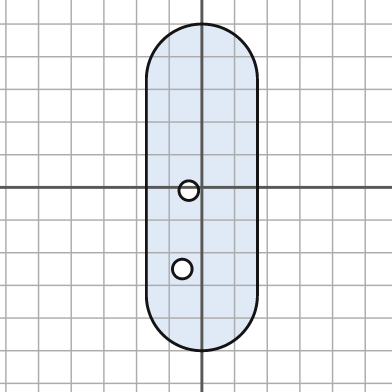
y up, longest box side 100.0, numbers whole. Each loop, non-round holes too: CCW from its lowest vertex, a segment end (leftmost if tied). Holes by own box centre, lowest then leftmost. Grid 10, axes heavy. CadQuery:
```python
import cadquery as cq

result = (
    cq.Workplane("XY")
    .moveTo(-17.0, -33.0)
    .threePointArc((0.0, -50.0), (17.0, -33.0))
    .lineTo(17.0, 33.0)
    .threePointArc((0.0, 50.0), (-17.0, 33.0))
    .close()
    .moveTo(-6.0, -25.0)
    .circle(3.0)
    .moveTo(-4.0, -1.0)
    .circle(3.0)
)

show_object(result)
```